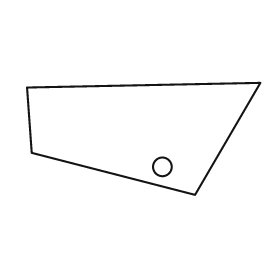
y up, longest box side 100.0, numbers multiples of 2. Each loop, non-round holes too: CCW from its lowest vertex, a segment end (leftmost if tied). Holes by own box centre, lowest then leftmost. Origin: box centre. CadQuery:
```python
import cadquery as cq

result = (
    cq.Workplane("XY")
    .moveTo(22.0, -24.0)
    .lineTo(50.0, 24.0)
    .lineTo(-50.0, 22.0)
    .lineTo(-48.0, -6.0)
    .close()
    .moveTo(8.0, -12.0)
    .circle(4.0)
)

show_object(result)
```